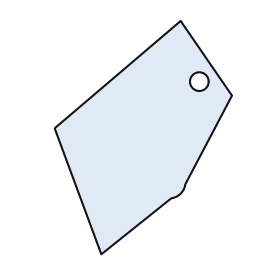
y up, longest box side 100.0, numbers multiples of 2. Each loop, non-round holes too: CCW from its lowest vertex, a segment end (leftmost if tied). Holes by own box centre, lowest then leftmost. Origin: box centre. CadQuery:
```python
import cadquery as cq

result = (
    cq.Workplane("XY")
    .moveTo(-18.0, -50.0)
    .lineTo(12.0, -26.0)
    .threePointArc((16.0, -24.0), (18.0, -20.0))
    .lineTo(38.0, 18.0)
    .lineTo(16.0, 50.0)
    .lineTo(-38.0, 4.0)
    .close()
    .moveTo(24.0, 24.0)
    .circle(4.0)
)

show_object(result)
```